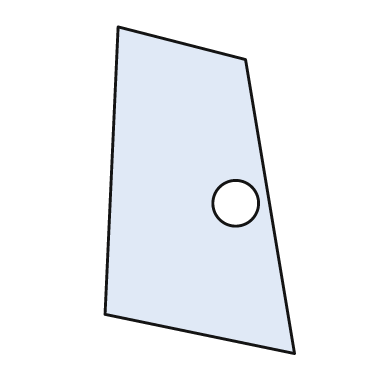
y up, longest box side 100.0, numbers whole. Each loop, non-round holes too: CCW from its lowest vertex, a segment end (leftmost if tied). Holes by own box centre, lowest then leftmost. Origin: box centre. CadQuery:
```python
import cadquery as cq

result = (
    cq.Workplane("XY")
    .moveTo(29.0, -50.0)
    .lineTo(14.0, 40.0)
    .lineTo(-25.0, 50.0)
    .lineTo(-29.0, -38.0)
    .close()
    .moveTo(11.0, -4.0)
    .circle(7.0)
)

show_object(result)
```